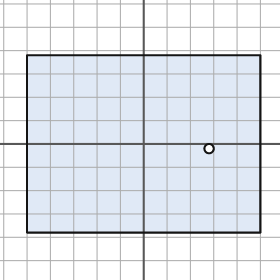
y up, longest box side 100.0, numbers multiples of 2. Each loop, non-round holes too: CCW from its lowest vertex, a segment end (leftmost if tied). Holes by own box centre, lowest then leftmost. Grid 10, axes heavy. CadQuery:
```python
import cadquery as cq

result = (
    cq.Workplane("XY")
    .moveTo(-50.0, -38.0)
    .lineTo(50.0, -38.0)
    .lineTo(50.0, 38.0)
    .lineTo(-50.0, 38.0)
    .close()
    .moveTo(28.0, -2.0)
    .circle(2.0)
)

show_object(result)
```